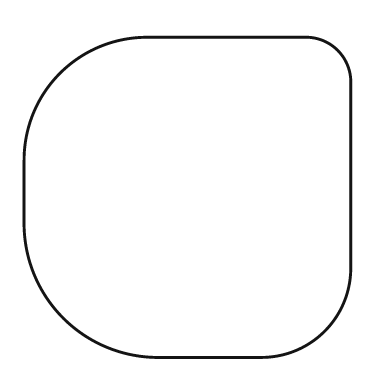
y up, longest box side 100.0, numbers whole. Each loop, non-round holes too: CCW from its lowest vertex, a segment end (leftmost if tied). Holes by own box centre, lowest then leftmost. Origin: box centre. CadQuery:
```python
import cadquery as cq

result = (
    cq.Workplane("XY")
    .moveTo(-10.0, -49.0)
    .lineTo(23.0, -49.0)
    .threePointArc((42.0, -41.0), (50.0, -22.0))
    .lineTo(50.0, 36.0)
    .threePointArc((46.0, 45.0), (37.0, 49.0))
    .lineTo(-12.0, 49.0)
    .threePointArc((-39.0, 38.0), (-50.0, 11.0))
    .lineTo(-50.0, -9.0)
    .threePointArc((-38.0, -37.0), (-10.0, -49.0))
    .close()
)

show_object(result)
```